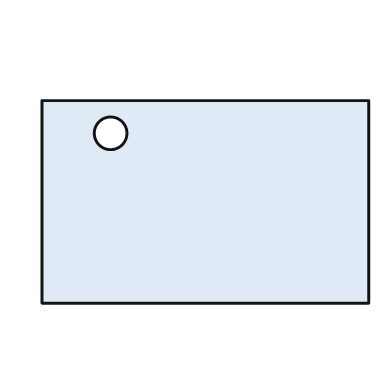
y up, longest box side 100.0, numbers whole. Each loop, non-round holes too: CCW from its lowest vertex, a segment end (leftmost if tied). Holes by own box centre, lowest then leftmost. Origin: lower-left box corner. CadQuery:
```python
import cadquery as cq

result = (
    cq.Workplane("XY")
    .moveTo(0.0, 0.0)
    .lineTo(100.0, 0.0)
    .lineTo(100.0, 62.0)
    .lineTo(0.0, 62.0)
    .close()
    .moveTo(21.0, 52.0)
    .circle(5.0)
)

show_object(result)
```